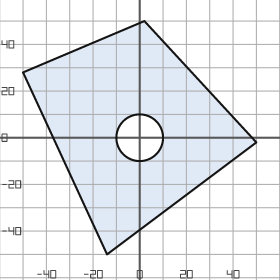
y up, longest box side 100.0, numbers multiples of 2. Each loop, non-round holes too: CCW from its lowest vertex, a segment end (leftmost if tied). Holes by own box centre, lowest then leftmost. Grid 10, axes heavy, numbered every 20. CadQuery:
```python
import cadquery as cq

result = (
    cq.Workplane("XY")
    .moveTo(-14.0, -50.0)
    .lineTo(50.0, -2.0)
    .lineTo(2.0, 50.0)
    .lineTo(-50.0, 28.0)
    .close()
    .moveTo(0.0, 0.0)
    .circle(10.0)
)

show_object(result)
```